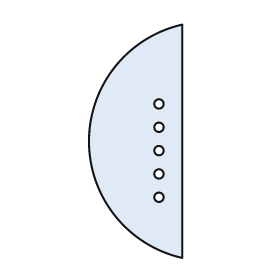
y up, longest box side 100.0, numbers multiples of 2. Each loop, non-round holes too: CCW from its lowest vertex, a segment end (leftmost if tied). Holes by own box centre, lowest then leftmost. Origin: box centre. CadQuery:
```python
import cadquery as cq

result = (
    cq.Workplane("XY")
    .moveTo(20.0, -50.0)
    .lineTo(20.0, 50.0)
    .threePointArc((-20.0, 0.0), (20.0, -50.0))
    .close()
    .moveTo(10.0, -24.0)
    .circle(2.0)
    .moveTo(10.0, -14.0)
    .circle(2.0)
    .moveTo(10.0, -4.0)
    .circle(2.0)
    .moveTo(10.0, 6.0)
    .circle(2.0)
    .moveTo(10.0, 16.0)
    .circle(2.0)
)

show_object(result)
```